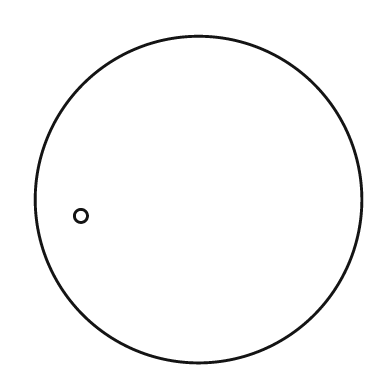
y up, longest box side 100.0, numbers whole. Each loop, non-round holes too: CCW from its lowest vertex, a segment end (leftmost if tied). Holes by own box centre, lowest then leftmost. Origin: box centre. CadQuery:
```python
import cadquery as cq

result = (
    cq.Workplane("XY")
    .moveTo(0.0, 0.0)
    .circle(50.0)
    .moveTo(-36.0, -5.0)
    .circle(2.0)
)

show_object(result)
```